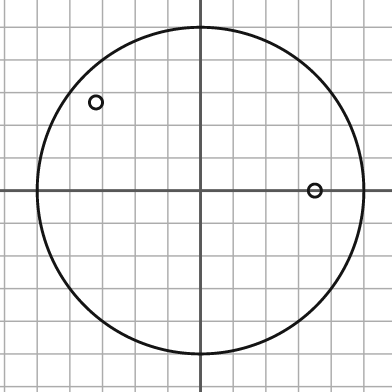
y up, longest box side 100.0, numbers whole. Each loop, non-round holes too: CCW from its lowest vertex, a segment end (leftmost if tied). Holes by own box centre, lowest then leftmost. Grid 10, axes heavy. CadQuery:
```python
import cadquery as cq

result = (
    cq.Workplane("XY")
    .moveTo(0.0, 0.0)
    .circle(50.0)
    .moveTo(35.0, 0.0)
    .circle(2.0)
    .moveTo(-32.0, 27.0)
    .circle(2.0)
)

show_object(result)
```